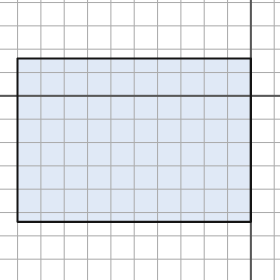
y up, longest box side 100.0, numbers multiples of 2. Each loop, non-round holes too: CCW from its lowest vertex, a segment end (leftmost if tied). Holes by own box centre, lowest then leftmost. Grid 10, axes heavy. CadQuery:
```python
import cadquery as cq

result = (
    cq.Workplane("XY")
    .moveTo(-100.0, -54.0)
    .lineTo(0.0, -54.0)
    .lineTo(0.0, 16.0)
    .lineTo(-100.0, 16.0)
    .close()
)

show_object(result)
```